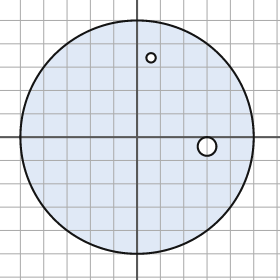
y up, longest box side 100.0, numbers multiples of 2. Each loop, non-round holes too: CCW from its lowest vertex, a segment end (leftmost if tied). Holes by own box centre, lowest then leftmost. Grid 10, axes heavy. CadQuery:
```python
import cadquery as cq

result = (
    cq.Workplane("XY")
    .moveTo(0.0, 0.0)
    .circle(50.0)
    .moveTo(30.0, -4.0)
    .circle(4.0)
    .moveTo(6.0, 34.0)
    .circle(2.0)
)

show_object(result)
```